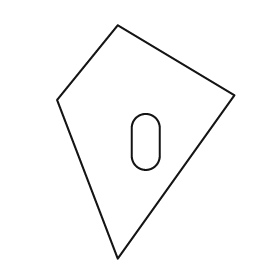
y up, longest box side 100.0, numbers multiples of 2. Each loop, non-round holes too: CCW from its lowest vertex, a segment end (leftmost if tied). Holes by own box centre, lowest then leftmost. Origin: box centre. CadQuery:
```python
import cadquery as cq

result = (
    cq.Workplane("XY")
    .moveTo(-12.0, -50.0)
    .lineTo(38.0, 20.0)
    .lineTo(-12.0, 50.0)
    .lineTo(-38.0, 18.0)
    .close()
    .moveTo(-6.0, -6.0)
    .threePointArc((0.0, -12.0), (6.0, -6.0))
    .lineTo(6.0, 6.0)
    .threePointArc((0.0, 12.0), (-6.0, 6.0))
    .close()
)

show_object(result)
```